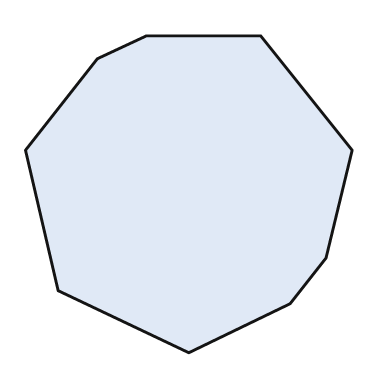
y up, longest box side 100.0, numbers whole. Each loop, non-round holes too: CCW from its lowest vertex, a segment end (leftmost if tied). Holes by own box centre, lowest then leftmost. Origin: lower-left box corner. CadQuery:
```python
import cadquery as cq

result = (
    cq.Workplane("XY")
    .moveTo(50.0, 0.0)
    .lineTo(81.0, 15.0)
    .lineTo(92.0, 29.0)
    .lineTo(100.0, 62.0)
    .lineTo(72.0, 97.0)
    .lineTo(37.0, 97.0)
    .lineTo(22.0, 90.0)
    .lineTo(0.0, 62.0)
    .lineTo(10.0, 19.0)
    .close()
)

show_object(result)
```